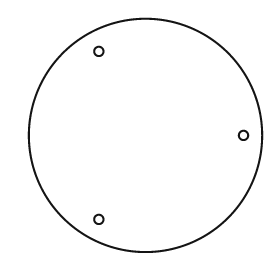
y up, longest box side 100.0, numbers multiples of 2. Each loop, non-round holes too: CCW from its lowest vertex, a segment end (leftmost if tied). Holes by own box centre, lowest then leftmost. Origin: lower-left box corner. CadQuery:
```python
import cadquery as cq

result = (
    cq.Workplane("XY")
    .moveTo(50.0, 50.0)
    .circle(50.0)
    .moveTo(30.0, 14.0)
    .circle(2.0)
    .moveTo(92.0, 50.0)
    .circle(2.0)
    .moveTo(30.0, 86.0)
    .circle(2.0)
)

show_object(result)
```